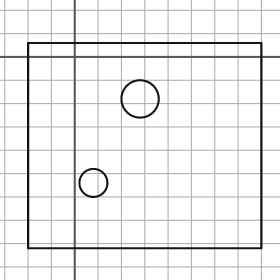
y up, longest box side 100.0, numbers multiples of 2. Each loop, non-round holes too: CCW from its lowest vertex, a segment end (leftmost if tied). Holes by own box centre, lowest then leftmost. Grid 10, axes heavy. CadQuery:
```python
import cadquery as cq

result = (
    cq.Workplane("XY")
    .moveTo(-20.0, -82.0)
    .lineTo(80.0, -82.0)
    .lineTo(80.0, 6.0)
    .lineTo(-20.0, 6.0)
    .close()
    .moveTo(8.0, -54.0)
    .circle(6.0)
    .moveTo(28.0, -18.0)
    .circle(8.0)
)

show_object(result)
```